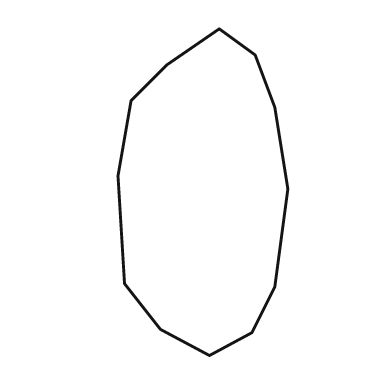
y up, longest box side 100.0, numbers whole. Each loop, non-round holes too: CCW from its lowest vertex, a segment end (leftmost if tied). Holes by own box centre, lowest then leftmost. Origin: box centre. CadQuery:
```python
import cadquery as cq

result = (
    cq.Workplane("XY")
    .moveTo(2.0, -50.0)
    .lineTo(15.0, -43.0)
    .lineTo(22.0, -29.0)
    .lineTo(26.0, 1.0)
    .lineTo(22.0, 26.0)
    .lineTo(16.0, 42.0)
    .lineTo(5.0, 50.0)
    .lineTo(-11.0, 39.0)
    .lineTo(-22.0, 28.0)
    .lineTo(-26.0, 5.0)
    .lineTo(-24.0, -28.0)
    .lineTo(-13.0, -42.0)
    .close()
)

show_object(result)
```